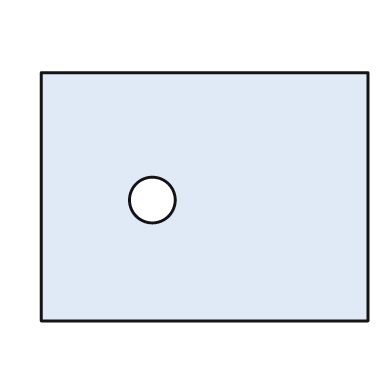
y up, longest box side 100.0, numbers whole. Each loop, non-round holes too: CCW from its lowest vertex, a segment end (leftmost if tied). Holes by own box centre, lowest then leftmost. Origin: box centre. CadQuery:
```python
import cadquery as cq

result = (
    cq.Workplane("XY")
    .moveTo(-50.0, -38.0)
    .lineTo(50.0, -38.0)
    .lineTo(50.0, 38.0)
    .lineTo(-50.0, 38.0)
    .close()
    .moveTo(-16.0, -1.0)
    .circle(7.0)
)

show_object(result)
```